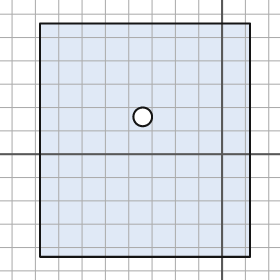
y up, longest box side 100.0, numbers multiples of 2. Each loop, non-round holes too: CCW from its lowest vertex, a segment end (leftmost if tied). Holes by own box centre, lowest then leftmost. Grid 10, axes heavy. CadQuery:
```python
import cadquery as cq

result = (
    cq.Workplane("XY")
    .moveTo(-78.0, -44.0)
    .lineTo(12.0, -44.0)
    .lineTo(12.0, 56.0)
    .lineTo(-78.0, 56.0)
    .close()
    .moveTo(-34.0, 16.0)
    .circle(4.0)
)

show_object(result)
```